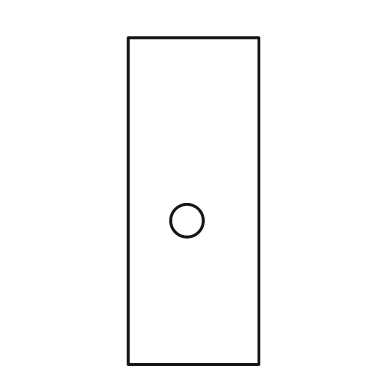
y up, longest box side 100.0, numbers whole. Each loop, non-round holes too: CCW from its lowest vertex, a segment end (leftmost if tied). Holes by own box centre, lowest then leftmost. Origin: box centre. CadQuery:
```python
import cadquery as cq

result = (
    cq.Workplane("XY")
    .moveTo(-20.0, -50.0)
    .lineTo(20.0, -50.0)
    .lineTo(20.0, 50.0)
    .lineTo(-20.0, 50.0)
    .close()
    .moveTo(-2.0, -6.0)
    .circle(5.0)
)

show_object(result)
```